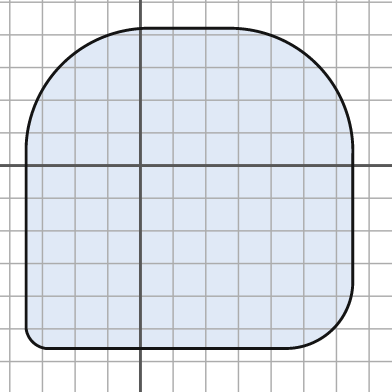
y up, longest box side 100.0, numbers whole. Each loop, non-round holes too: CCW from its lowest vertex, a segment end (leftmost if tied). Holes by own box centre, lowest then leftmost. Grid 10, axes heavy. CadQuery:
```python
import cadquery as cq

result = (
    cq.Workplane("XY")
    .moveTo(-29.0, -56.0)
    .lineTo(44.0, -56.0)
    .threePointArc((59.0, -50.0), (65.0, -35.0))
    .lineTo(65.0, 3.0)
    .threePointArc((54.0, 31.0), (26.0, 42.0))
    .lineTo(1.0, 42.0)
    .threePointArc((-24.0, 31.0), (-35.0, 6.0))
    .lineTo(-35.0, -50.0)
    .threePointArc((-33.0, -54.0), (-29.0, -56.0))
    .close()
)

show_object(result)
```